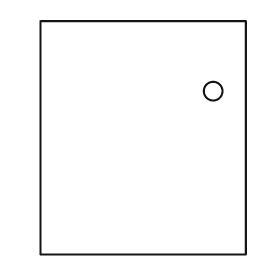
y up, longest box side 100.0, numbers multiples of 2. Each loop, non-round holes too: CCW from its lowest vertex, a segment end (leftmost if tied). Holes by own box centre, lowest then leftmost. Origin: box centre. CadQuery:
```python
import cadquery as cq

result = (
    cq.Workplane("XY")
    .moveTo(-44.0, -50.0)
    .lineTo(44.0, -50.0)
    .lineTo(44.0, 50.0)
    .lineTo(-44.0, 50.0)
    .close()
    .moveTo(30.0, 20.0)
    .circle(4.0)
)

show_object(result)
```